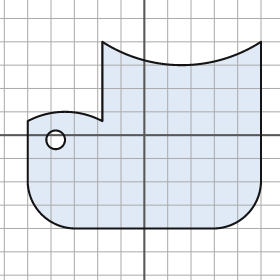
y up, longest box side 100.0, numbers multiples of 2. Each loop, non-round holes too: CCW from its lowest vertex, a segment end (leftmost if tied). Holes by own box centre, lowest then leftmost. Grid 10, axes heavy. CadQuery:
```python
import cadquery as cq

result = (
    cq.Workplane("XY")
    .moveTo(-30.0, -40.0)
    .lineTo(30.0, -40.0)
    .threePointArc((44.0, -34.0), (50.0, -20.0))
    .lineTo(50.0, 40.0)
    .threePointArc((16.0, 30.0), (-18.0, 40.0))
    .lineTo(-18.0, 6.0)
    .threePointArc((-34.0, 10.0), (-50.0, 6.0))
    .lineTo(-50.0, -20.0)
    .threePointArc((-44.0, -34.0), (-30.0, -40.0))
    .close()
    .moveTo(-38.0, -2.0)
    .circle(4.0)
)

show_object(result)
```